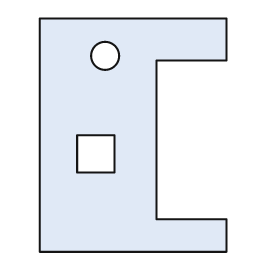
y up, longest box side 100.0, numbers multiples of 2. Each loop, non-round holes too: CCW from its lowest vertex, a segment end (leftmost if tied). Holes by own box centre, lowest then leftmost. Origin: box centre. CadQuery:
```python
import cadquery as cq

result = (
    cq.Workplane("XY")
    .moveTo(-40.0, -50.0)
    .lineTo(40.0, -50.0)
    .lineTo(40.0, -36.0)
    .lineTo(10.0, -36.0)
    .lineTo(10.0, 32.0)
    .lineTo(40.0, 32.0)
    .lineTo(40.0, 50.0)
    .lineTo(-40.0, 50.0)
    .close()
    .moveTo(-24.0, -16.0)
    .lineTo(-8.0, -16.0)
    .lineTo(-8.0, 0.0)
    .lineTo(-24.0, 0.0)
    .close()
    .moveTo(-12.0, 34.0)
    .circle(6.0)
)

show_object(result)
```